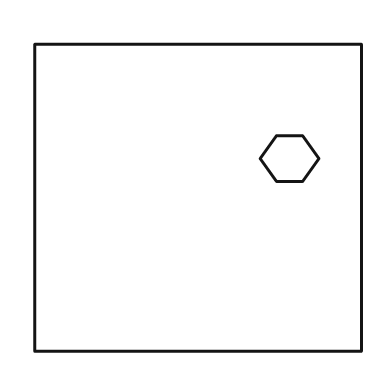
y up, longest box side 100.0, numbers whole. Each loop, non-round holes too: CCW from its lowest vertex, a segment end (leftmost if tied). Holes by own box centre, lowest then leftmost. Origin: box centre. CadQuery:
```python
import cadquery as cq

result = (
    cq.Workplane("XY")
    .moveTo(-50.0, -47.0)
    .lineTo(50.0, -47.0)
    .lineTo(50.0, 47.0)
    .lineTo(-50.0, 47.0)
    .close()
    .moveTo(24.0, 5.0)
    .lineTo(32.0, 5.0)
    .lineTo(37.0, 12.0)
    .lineTo(32.0, 19.0)
    .lineTo(24.0, 19.0)
    .lineTo(19.0, 12.0)
    .close()
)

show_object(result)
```